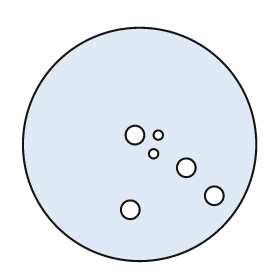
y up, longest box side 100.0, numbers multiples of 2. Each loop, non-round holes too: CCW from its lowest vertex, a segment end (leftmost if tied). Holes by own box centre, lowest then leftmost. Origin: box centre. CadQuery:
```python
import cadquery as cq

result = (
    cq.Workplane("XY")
    .moveTo(0.0, 0.0)
    .circle(50.0)
    .moveTo(-4.0, -28.0)
    .circle(4.0)
    .moveTo(32.0, -22.0)
    .circle(4.0)
    .moveTo(20.0, -10.0)
    .circle(4.0)
    .moveTo(6.0, -4.0)
    .circle(2.0)
    .moveTo(-2.0, 4.0)
    .circle(4.0)
    .moveTo(8.0, 4.0)
    .circle(2.0)
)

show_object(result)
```